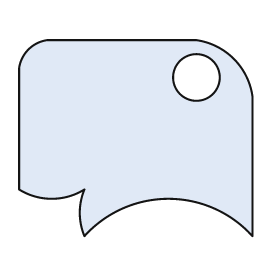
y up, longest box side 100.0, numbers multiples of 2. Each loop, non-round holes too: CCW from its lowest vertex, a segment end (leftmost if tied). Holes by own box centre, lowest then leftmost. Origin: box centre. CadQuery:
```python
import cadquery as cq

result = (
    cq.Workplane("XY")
    .moveTo(-22.0, -42.0)
    .threePointArc((14.0, -26.0), (50.0, -42.0))
    .lineTo(50.0, 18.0)
    .threePointArc((42.0, 34.0), (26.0, 42.0))
    .lineTo(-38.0, 42.0)
    .threePointArc((-46.0, 38.0), (-50.0, 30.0))
    .lineTo(-50.0, -22.0)
    .threePointArc((-36.0, -26.0), (-22.0, -22.0))
    .threePointArc((-24.0, -32.0), (-22.0, -42.0))
    .close()
    .moveTo(26.0, 26.0)
    .circle(10.0)
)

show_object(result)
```